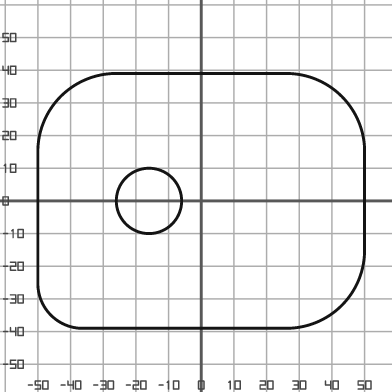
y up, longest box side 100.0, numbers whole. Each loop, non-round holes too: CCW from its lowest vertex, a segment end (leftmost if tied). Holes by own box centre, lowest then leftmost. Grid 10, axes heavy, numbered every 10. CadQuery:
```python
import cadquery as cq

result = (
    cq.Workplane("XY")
    .moveTo(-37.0, -39.0)
    .lineTo(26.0, -39.0)
    .threePointArc((43.0, -32.0), (50.0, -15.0))
    .lineTo(50.0, 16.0)
    .threePointArc((43.0, 32.0), (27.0, 39.0))
    .lineTo(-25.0, 39.0)
    .threePointArc((-43.0, 32.0), (-50.0, 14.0))
    .lineTo(-50.0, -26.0)
    .threePointArc((-46.0, -35.0), (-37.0, -39.0))
    .close()
    .moveTo(-16.0, 0.0)
    .circle(10.0)
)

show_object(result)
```